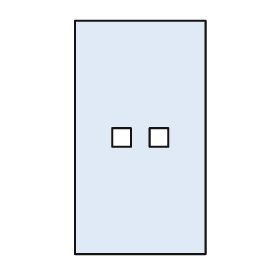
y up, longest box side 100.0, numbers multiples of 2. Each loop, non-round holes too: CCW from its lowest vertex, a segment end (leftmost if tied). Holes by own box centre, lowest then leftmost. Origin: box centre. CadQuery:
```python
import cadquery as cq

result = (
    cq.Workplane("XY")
    .moveTo(-28.0, -50.0)
    .lineTo(28.0, -50.0)
    .lineTo(28.0, 50.0)
    .lineTo(-28.0, 50.0)
    .close()
    .moveTo(-12.0, -4.0)
    .lineTo(-4.0, -4.0)
    .lineTo(-4.0, 4.0)
    .lineTo(-12.0, 4.0)
    .close()
    .moveTo(4.0, -4.0)
    .lineTo(12.0, -4.0)
    .lineTo(12.0, 4.0)
    .lineTo(4.0, 4.0)
    .close()
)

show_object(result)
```